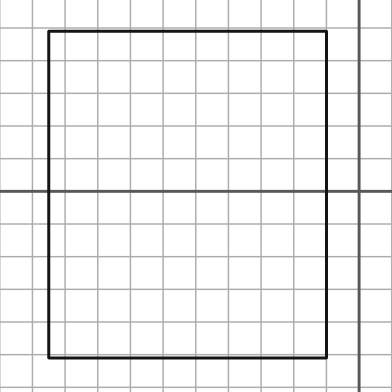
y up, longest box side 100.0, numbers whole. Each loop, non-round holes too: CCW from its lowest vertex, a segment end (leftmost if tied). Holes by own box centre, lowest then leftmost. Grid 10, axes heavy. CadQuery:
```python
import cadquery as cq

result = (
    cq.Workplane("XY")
    .moveTo(-95.0, -51.0)
    .lineTo(-10.0, -51.0)
    .lineTo(-10.0, 49.0)
    .lineTo(-95.0, 49.0)
    .close()
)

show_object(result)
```